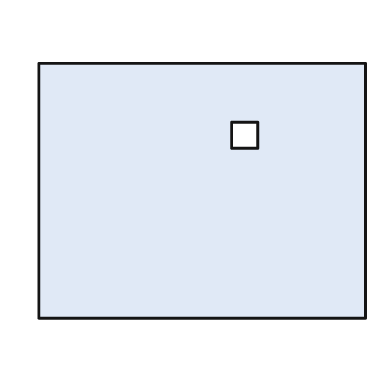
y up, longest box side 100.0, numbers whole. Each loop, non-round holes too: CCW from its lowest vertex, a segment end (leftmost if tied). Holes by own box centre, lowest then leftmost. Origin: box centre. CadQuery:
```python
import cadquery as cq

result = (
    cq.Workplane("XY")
    .moveTo(-50.0, -39.0)
    .lineTo(50.0, -39.0)
    .lineTo(50.0, 39.0)
    .lineTo(-50.0, 39.0)
    .close()
    .moveTo(9.0, 13.0)
    .lineTo(17.0, 13.0)
    .lineTo(17.0, 21.0)
    .lineTo(9.0, 21.0)
    .close()
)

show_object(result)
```